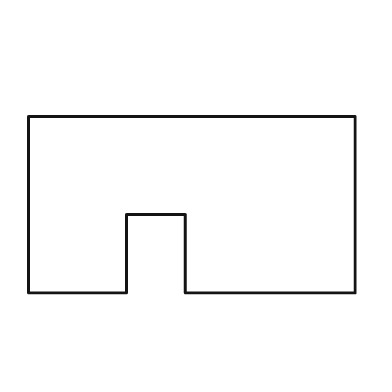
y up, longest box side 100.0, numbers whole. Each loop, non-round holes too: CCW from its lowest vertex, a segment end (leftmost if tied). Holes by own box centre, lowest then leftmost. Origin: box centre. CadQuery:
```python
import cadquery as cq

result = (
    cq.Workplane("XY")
    .moveTo(-50.0, -27.0)
    .lineTo(-20.0, -27.0)
    .lineTo(-20.0, -3.0)
    .lineTo(-2.0, -3.0)
    .lineTo(-2.0, -27.0)
    .lineTo(50.0, -27.0)
    .lineTo(50.0, 27.0)
    .lineTo(-50.0, 27.0)
    .close()
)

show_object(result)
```